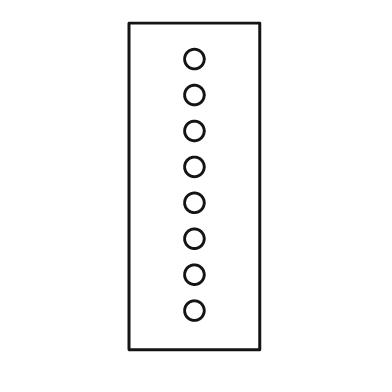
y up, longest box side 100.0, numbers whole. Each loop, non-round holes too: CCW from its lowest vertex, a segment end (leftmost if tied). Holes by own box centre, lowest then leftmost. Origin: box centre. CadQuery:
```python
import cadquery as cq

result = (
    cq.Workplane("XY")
    .moveTo(-20.0, -50.0)
    .lineTo(20.0, -50.0)
    .lineTo(20.0, 50.0)
    .lineTo(-20.0, 50.0)
    .close()
    .moveTo(0.0, -38.0)
    .circle(3.0)
    .moveTo(0.0, -27.0)
    .circle(3.0)
    .moveTo(0.0, -16.0)
    .circle(3.0)
    .moveTo(0.0, -5.0)
    .circle(3.0)
    .moveTo(0.0, 6.0)
    .circle(3.0)
    .moveTo(0.0, 17.0)
    .circle(3.0)
    .moveTo(0.0, 28.0)
    .circle(3.0)
    .moveTo(0.0, 39.0)
    .circle(3.0)
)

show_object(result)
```